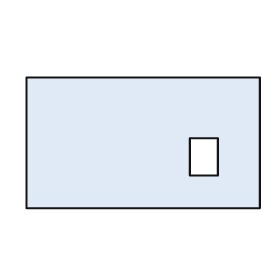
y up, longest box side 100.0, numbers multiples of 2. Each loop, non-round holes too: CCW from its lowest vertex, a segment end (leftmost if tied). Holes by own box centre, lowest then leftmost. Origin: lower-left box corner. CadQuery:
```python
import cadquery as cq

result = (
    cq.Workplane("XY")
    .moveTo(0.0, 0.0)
    .lineTo(100.0, 0.0)
    .lineTo(100.0, 56.0)
    .lineTo(0.0, 56.0)
    .close()
    .moveTo(70.0, 14.0)
    .lineTo(82.0, 14.0)
    .lineTo(82.0, 30.0)
    .lineTo(70.0, 30.0)
    .close()
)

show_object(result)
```